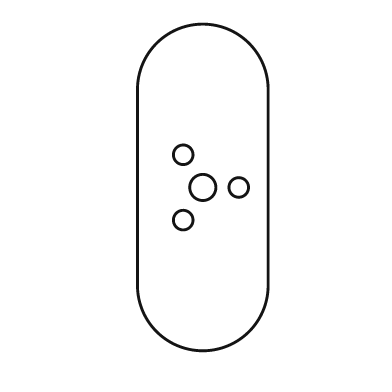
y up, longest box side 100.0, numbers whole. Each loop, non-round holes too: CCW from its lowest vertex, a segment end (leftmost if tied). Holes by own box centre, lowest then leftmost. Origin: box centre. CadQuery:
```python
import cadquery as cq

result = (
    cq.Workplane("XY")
    .moveTo(-20.0, -30.0)
    .threePointArc((0.0, -50.0), (20.0, -30.0))
    .lineTo(20.0, 30.0)
    .threePointArc((0.0, 50.0), (-20.0, 30.0))
    .close()
    .moveTo(-6.0, -10.0)
    .circle(3.0)
    .moveTo(0.0, 0.0)
    .circle(4.0)
    .moveTo(11.0, 0.0)
    .circle(3.0)
    .moveTo(-6.0, 10.0)
    .circle(3.0)
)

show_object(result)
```